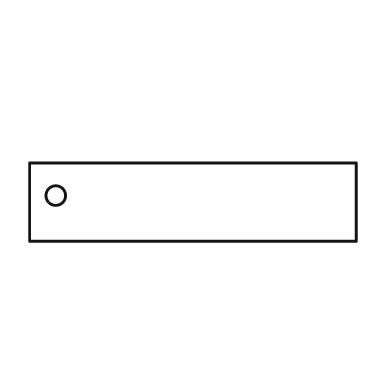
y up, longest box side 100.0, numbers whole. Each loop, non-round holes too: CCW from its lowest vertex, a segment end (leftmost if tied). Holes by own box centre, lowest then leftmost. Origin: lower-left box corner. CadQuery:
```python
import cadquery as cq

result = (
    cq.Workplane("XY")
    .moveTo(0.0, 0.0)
    .lineTo(100.0, 0.0)
    .lineTo(100.0, 24.0)
    .lineTo(0.0, 24.0)
    .close()
    .moveTo(8.0, 14.0)
    .circle(3.0)
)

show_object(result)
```